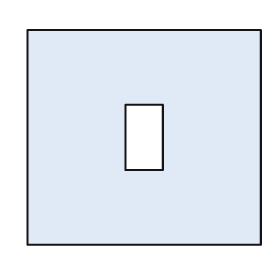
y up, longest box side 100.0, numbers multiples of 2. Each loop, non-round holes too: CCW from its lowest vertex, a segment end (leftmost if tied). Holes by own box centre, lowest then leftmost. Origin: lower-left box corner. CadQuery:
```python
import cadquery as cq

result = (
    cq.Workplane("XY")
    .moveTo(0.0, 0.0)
    .lineTo(100.0, 0.0)
    .lineTo(100.0, 92.0)
    .lineTo(0.0, 92.0)
    .close()
    .moveTo(42.0, 32.0)
    .lineTo(58.0, 32.0)
    .lineTo(58.0, 60.0)
    .lineTo(42.0, 60.0)
    .close()
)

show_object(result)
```